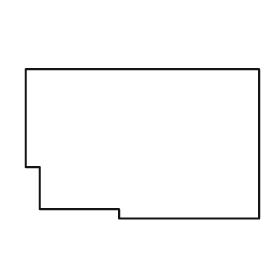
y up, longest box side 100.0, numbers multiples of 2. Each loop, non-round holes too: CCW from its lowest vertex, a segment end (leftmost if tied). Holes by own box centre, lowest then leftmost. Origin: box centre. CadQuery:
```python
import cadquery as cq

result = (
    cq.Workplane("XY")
    .moveTo(-10.0, -32.0)
    .lineTo(50.0, -32.0)
    .lineTo(50.0, 32.0)
    .lineTo(-50.0, 32.0)
    .lineTo(-50.0, -10.0)
    .lineTo(-44.0, -10.0)
    .lineTo(-44.0, -28.0)
    .lineTo(-10.0, -28.0)
    .close()
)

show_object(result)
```